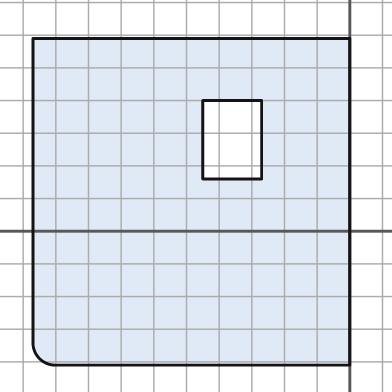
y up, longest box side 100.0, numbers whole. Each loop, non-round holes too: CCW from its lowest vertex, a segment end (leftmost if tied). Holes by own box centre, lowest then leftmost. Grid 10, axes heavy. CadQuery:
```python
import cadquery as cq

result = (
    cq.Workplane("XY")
    .moveTo(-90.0, -41.0)
    .lineTo(0.0, -41.0)
    .lineTo(0.0, 59.0)
    .lineTo(-97.0, 59.0)
    .lineTo(-97.0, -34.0)
    .threePointArc((-95.0, -39.0), (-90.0, -41.0))
    .close()
    .moveTo(-45.0, 16.0)
    .lineTo(-27.0, 16.0)
    .lineTo(-27.0, 40.0)
    .lineTo(-45.0, 40.0)
    .close()
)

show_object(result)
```